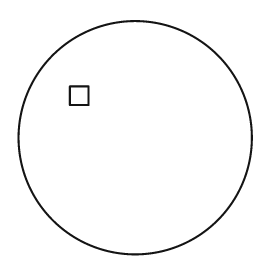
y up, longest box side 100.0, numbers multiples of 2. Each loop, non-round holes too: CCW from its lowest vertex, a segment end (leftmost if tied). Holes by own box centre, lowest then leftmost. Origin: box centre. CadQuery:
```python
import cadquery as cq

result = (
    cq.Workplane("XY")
    .moveTo(0.0, 0.0)
    .circle(50.0)
    .moveTo(-28.0, 14.0)
    .lineTo(-20.0, 14.0)
    .lineTo(-20.0, 22.0)
    .lineTo(-28.0, 22.0)
    .close()
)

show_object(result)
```